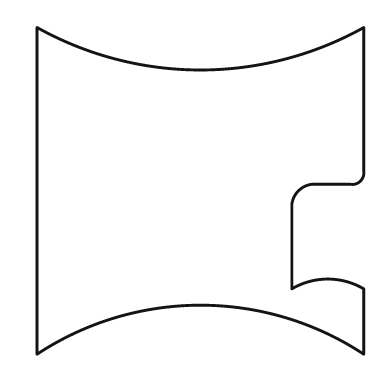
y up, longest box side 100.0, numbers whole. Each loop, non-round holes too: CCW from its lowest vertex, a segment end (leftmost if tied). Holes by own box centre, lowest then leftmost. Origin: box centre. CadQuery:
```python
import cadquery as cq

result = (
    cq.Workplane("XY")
    .moveTo(-50.0, -50.0)
    .threePointArc((0.0, -35.0), (50.0, -50.0))
    .lineTo(50.0, -30.0)
    .threePointArc((39.0, -27.0), (28.0, -30.0))
    .lineTo(28.0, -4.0)
    .threePointArc((30.0, 0.0), (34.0, 2.0))
    .lineTo(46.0, 2.0)
    .threePointArc((49.0, 3.0), (50.0, 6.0))
    .lineTo(50.0, 50.0)
    .threePointArc((0.0, 37.0), (-50.0, 50.0))
    .close()
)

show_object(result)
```